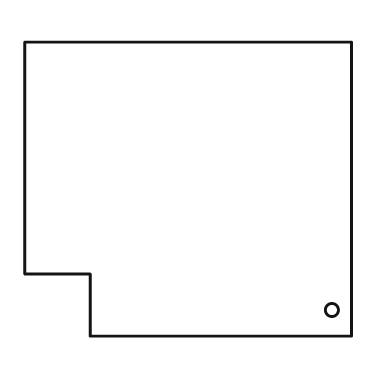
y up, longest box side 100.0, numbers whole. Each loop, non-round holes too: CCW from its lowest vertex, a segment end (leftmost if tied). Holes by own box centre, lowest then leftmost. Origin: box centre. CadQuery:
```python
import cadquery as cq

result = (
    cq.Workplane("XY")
    .moveTo(-30.0, -45.0)
    .lineTo(50.0, -45.0)
    .lineTo(50.0, 45.0)
    .lineTo(-50.0, 45.0)
    .lineTo(-50.0, -26.0)
    .lineTo(-30.0, -26.0)
    .close()
    .moveTo(44.0, -37.0)
    .circle(2.0)
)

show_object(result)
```